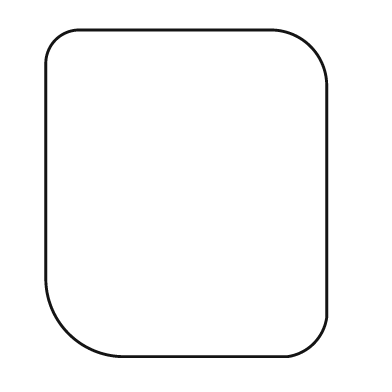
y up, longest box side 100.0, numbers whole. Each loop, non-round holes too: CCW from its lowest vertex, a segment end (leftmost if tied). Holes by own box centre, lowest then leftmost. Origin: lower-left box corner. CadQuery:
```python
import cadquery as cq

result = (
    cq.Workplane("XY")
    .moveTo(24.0, 0.0)
    .lineTo(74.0, 0.0)
    .threePointArc((82.0, 4.0), (86.0, 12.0))
    .lineTo(86.0, 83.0)
    .threePointArc((81.0, 95.0), (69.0, 100.0))
    .lineTo(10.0, 100.0)
    .threePointArc((3.0, 97.0), (0.0, 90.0))
    .lineTo(0.0, 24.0)
    .threePointArc((7.0, 7.0), (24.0, 0.0))
    .close()
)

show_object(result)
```